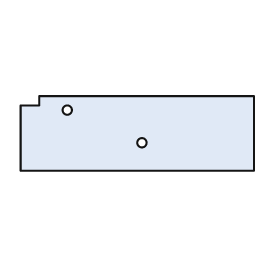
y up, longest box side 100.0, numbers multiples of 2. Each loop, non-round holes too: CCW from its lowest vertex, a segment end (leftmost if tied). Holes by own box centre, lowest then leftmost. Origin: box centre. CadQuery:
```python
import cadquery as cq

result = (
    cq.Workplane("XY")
    .moveTo(-50.0, -16.0)
    .lineTo(50.0, -16.0)
    .lineTo(50.0, 16.0)
    .lineTo(-42.0, 16.0)
    .lineTo(-42.0, 12.0)
    .lineTo(-50.0, 12.0)
    .close()
    .moveTo(2.0, -4.0)
    .circle(2.0)
    .moveTo(-30.0, 10.0)
    .circle(2.0)
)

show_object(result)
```